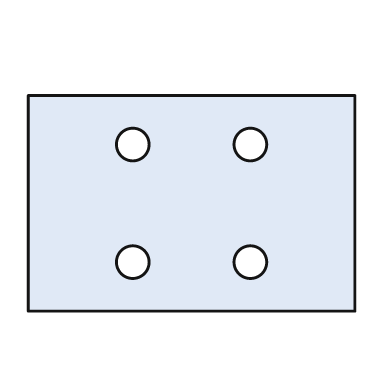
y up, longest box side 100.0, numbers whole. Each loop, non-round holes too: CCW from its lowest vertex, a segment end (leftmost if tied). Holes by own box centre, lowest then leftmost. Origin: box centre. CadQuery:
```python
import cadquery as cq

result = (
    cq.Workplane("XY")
    .moveTo(-50.0, -33.0)
    .lineTo(50.0, -33.0)
    .lineTo(50.0, 33.0)
    .lineTo(-50.0, 33.0)
    .close()
    .moveTo(-18.0, -18.0)
    .circle(5.0)
    .moveTo(18.0, -18.0)
    .circle(5.0)
    .moveTo(-18.0, 18.0)
    .circle(5.0)
    .moveTo(18.0, 18.0)
    .circle(5.0)
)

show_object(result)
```